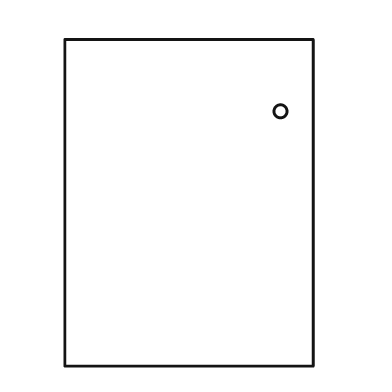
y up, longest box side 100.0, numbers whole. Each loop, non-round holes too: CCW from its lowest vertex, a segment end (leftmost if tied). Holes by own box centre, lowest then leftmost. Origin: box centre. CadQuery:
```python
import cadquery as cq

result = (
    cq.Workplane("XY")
    .moveTo(-38.0, -50.0)
    .lineTo(38.0, -50.0)
    .lineTo(38.0, 50.0)
    .lineTo(-38.0, 50.0)
    .close()
    .moveTo(28.0, 28.0)
    .circle(2.0)
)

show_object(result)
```